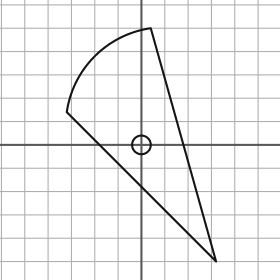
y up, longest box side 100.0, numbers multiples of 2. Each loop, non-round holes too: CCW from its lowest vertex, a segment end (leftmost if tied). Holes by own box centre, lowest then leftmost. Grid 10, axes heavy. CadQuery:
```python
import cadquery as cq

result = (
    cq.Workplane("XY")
    .moveTo(32.0, -50.0)
    .lineTo(4.0, 50.0)
    .threePointArc((-20.0, 38.0), (-32.0, 14.0))
    .close()
    .moveTo(0.0, 0.0)
    .circle(4.0)
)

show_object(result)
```